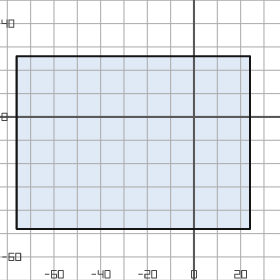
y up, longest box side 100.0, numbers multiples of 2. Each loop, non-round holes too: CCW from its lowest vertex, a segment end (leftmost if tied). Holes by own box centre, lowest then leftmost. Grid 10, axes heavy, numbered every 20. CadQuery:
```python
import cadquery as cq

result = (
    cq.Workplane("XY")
    .moveTo(-76.0, -48.0)
    .lineTo(24.0, -48.0)
    .lineTo(24.0, 26.0)
    .lineTo(-76.0, 26.0)
    .close()
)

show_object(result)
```